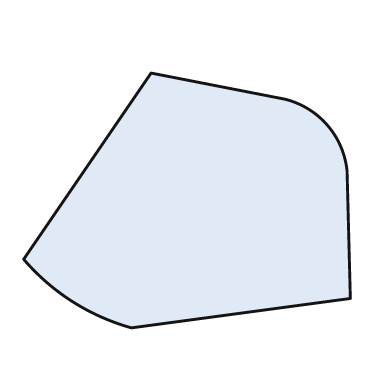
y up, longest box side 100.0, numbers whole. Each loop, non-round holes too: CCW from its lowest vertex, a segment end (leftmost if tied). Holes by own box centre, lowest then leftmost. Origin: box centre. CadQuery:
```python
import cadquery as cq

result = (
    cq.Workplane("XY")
    .moveTo(-17.0, -39.0)
    .lineTo(50.0, -30.0)
    .lineTo(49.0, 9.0)
    .threePointArc((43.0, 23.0), (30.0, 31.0))
    .lineTo(-11.0, 39.0)
    .lineTo(-50.0, -18.0)
    .threePointArc((-35.0, -31.0), (-17.0, -39.0))
    .close()
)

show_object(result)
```